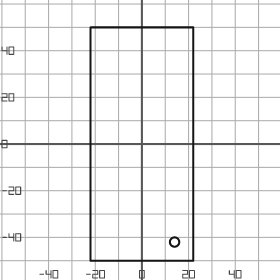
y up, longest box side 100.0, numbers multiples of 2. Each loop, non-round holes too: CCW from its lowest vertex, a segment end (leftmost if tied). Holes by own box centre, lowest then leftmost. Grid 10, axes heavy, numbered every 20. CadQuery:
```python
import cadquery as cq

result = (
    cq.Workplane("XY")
    .moveTo(-22.0, -50.0)
    .lineTo(22.0, -50.0)
    .lineTo(22.0, 50.0)
    .lineTo(-22.0, 50.0)
    .close()
    .moveTo(14.0, -42.0)
    .circle(2.0)
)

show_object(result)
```